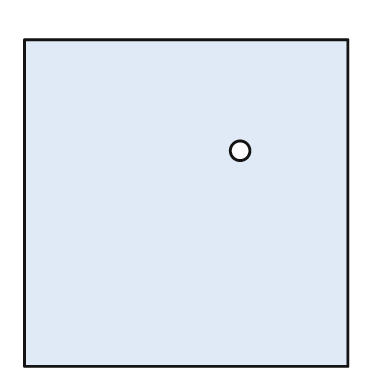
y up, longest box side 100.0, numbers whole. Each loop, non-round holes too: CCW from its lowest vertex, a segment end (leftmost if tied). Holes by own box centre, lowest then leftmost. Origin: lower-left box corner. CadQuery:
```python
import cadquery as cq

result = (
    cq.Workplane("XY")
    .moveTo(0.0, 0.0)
    .lineTo(99.0, 0.0)
    .lineTo(99.0, 100.0)
    .lineTo(0.0, 100.0)
    .close()
    .moveTo(66.0, 66.0)
    .circle(3.0)
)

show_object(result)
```